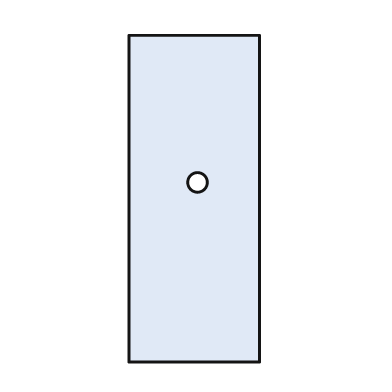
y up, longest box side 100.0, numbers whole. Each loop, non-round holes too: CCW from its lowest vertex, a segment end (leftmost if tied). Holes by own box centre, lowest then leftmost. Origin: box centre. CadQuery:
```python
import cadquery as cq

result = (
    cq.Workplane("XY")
    .moveTo(-20.0, -50.0)
    .lineTo(20.0, -50.0)
    .lineTo(20.0, 50.0)
    .lineTo(-20.0, 50.0)
    .close()
    .moveTo(1.0, 5.0)
    .circle(3.0)
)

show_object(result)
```